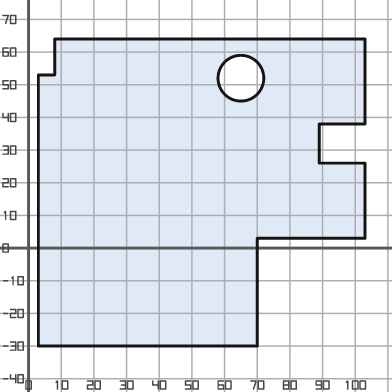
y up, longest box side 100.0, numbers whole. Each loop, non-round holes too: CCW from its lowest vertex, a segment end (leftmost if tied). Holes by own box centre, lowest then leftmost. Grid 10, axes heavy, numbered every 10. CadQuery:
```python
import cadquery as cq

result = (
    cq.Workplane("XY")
    .moveTo(3.0, -30.0)
    .lineTo(70.0, -30.0)
    .lineTo(70.0, 3.0)
    .lineTo(103.0, 3.0)
    .lineTo(103.0, 26.0)
    .lineTo(89.0, 26.0)
    .lineTo(89.0, 38.0)
    .lineTo(103.0, 38.0)
    .lineTo(103.0, 64.0)
    .lineTo(8.0, 64.0)
    .lineTo(8.0, 53.0)
    .lineTo(3.0, 53.0)
    .close()
    .moveTo(65.0, 52.0)
    .circle(7.0)
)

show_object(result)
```